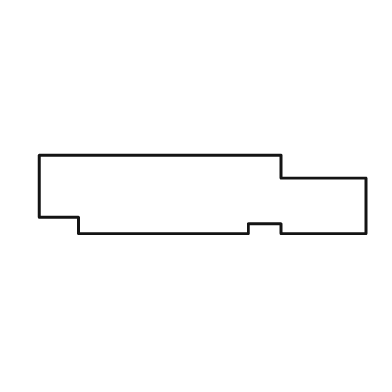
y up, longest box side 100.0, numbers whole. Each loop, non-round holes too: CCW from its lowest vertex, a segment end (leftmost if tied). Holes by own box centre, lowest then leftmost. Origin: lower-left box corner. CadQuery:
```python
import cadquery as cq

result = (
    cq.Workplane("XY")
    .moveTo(12.0, 0.0)
    .lineTo(64.0, 0.0)
    .lineTo(64.0, 3.0)
    .lineTo(74.0, 3.0)
    .lineTo(74.0, 0.0)
    .lineTo(100.0, 0.0)
    .lineTo(100.0, 17.0)
    .lineTo(74.0, 17.0)
    .lineTo(74.0, 24.0)
    .lineTo(0.0, 24.0)
    .lineTo(0.0, 5.0)
    .lineTo(12.0, 5.0)
    .close()
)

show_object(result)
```